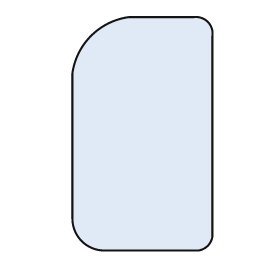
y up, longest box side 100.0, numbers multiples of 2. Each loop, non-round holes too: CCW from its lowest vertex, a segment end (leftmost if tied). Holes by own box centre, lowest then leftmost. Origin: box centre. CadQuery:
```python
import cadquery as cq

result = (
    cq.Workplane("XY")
    .moveTo(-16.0, -50.0)
    .lineTo(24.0, -50.0)
    .threePointArc((28.0, -48.0), (30.0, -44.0))
    .lineTo(30.0, 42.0)
    .threePointArc((28.0, 48.0), (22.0, 50.0))
    .lineTo(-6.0, 50.0)
    .threePointArc((-22.0, 42.0), (-30.0, 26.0))
    .lineTo(-30.0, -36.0)
    .threePointArc((-26.0, -46.0), (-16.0, -50.0))
    .close()
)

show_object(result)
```